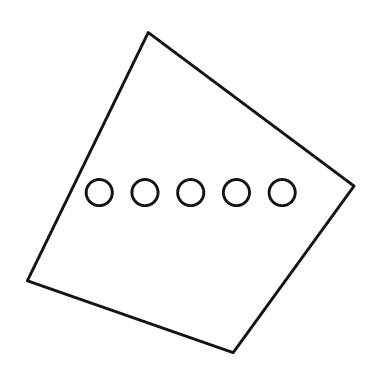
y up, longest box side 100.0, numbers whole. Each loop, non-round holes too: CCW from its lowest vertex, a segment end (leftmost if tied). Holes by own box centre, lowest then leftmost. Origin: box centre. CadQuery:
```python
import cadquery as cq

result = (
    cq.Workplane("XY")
    .moveTo(13.0, -49.0)
    .lineTo(50.0, 2.0)
    .lineTo(-13.0, 49.0)
    .lineTo(-50.0, -27.0)
    .close()
    .moveTo(-28.0, 0.0)
    .circle(4.0)
    .moveTo(-14.0, 0.0)
    .circle(4.0)
    .moveTo(0.0, 0.0)
    .circle(4.0)
    .moveTo(14.0, 0.0)
    .circle(4.0)
    .moveTo(28.0, 0.0)
    .circle(4.0)
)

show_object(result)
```